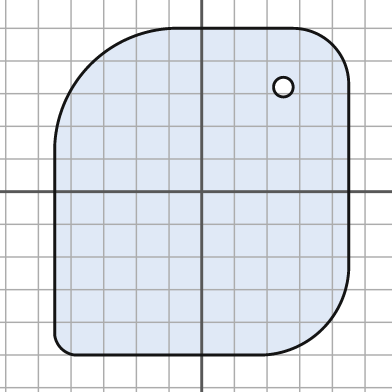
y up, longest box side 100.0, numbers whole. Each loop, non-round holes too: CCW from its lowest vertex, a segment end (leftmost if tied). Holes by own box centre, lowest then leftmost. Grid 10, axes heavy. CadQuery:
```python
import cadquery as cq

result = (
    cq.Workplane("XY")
    .moveTo(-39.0, -50.0)
    .lineTo(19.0, -50.0)
    .threePointArc((37.0, -42.0), (45.0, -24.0))
    .lineTo(45.0, 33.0)
    .threePointArc((40.0, 45.0), (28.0, 50.0))
    .lineTo(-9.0, 50.0)
    .threePointArc((-34.0, 39.0), (-45.0, 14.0))
    .lineTo(-45.0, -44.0)
    .threePointArc((-43.0, -48.0), (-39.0, -50.0))
    .close()
    .moveTo(25.0, 32.0)
    .circle(3.0)
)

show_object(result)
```